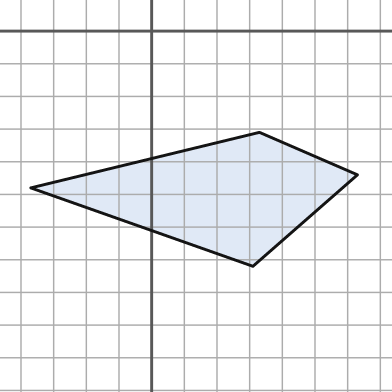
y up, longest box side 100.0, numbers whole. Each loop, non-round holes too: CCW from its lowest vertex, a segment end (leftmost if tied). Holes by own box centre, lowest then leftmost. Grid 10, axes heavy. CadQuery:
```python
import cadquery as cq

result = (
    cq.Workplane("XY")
    .moveTo(31.0, -72.0)
    .lineTo(63.0, -44.0)
    .lineTo(33.0, -31.0)
    .lineTo(-37.0, -48.0)
    .close()
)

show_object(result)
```